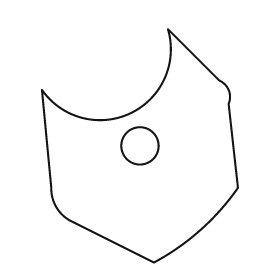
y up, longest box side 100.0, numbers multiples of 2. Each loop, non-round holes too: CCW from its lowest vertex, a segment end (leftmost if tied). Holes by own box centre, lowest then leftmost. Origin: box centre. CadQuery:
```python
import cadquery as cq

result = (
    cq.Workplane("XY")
    .moveTo(6.0, -50.0)
    .threePointArc((26.0, -36.0), (42.0, -18.0))
    .lineTo(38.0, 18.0)
    .threePointArc((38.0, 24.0), (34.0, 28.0))
    .lineTo(12.0, 50.0)
    .threePointArc((-4.0, 14.0), (-42.0, 24.0))
    .lineTo(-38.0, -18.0)
    .threePointArc((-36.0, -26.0), (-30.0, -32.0))
    .close()
    .moveTo(0.0, 0.0)
    .circle(8.0)
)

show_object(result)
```